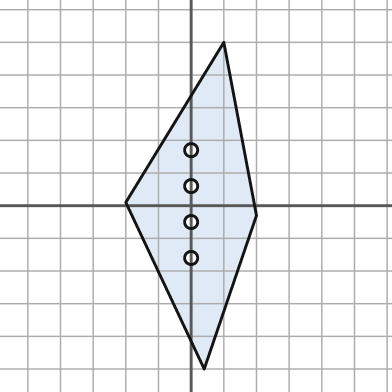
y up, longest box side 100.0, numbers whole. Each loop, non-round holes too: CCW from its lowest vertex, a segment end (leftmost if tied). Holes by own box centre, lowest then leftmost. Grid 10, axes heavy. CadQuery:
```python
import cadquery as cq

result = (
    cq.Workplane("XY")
    .moveTo(4.0, -50.0)
    .lineTo(20.0, -3.0)
    .lineTo(10.0, 50.0)
    .lineTo(-20.0, 1.0)
    .close()
    .moveTo(0.0, -16.0)
    .circle(2.0)
    .moveTo(0.0, -5.0)
    .circle(2.0)
    .moveTo(0.0, 6.0)
    .circle(2.0)
    .moveTo(0.0, 17.0)
    .circle(2.0)
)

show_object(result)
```